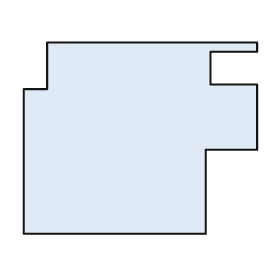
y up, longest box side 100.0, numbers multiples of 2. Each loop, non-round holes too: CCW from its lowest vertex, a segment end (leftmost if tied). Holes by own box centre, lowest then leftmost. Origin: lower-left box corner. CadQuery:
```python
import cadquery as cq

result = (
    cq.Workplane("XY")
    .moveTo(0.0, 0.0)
    .lineTo(78.0, 0.0)
    .lineTo(78.0, 36.0)
    .lineTo(100.0, 36.0)
    .lineTo(100.0, 64.0)
    .lineTo(80.0, 64.0)
    .lineTo(80.0, 78.0)
    .lineTo(100.0, 78.0)
    .lineTo(100.0, 82.0)
    .lineTo(10.0, 82.0)
    .lineTo(10.0, 62.0)
    .lineTo(0.0, 62.0)
    .close()
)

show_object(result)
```